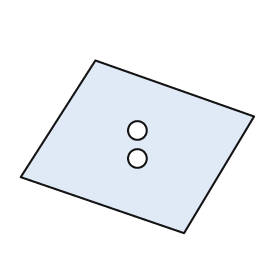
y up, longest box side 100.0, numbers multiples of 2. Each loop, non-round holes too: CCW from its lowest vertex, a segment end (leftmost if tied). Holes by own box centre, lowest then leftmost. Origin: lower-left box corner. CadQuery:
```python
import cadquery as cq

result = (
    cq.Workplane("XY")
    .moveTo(70.0, 0.0)
    .lineTo(100.0, 50.0)
    .lineTo(32.0, 74.0)
    .lineTo(0.0, 24.0)
    .close()
    .moveTo(50.0, 32.0)
    .circle(4.0)
    .moveTo(50.0, 44.0)
    .circle(4.0)
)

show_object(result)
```